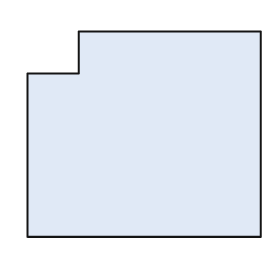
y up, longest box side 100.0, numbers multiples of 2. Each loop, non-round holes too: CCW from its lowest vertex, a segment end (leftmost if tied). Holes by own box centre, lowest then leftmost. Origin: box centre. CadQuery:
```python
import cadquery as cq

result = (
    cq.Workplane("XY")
    .moveTo(-50.0, -44.0)
    .lineTo(50.0, -44.0)
    .lineTo(50.0, 44.0)
    .lineTo(-28.0, 44.0)
    .lineTo(-28.0, 26.0)
    .lineTo(-50.0, 26.0)
    .close()
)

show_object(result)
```